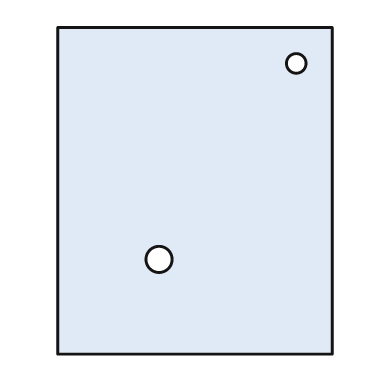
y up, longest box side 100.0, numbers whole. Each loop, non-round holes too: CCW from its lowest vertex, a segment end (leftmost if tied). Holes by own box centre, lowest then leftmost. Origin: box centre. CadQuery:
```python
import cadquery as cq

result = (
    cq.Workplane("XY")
    .moveTo(-42.0, -50.0)
    .lineTo(42.0, -50.0)
    .lineTo(42.0, 50.0)
    .lineTo(-42.0, 50.0)
    .close()
    .moveTo(-11.0, -21.0)
    .circle(4.0)
    .moveTo(31.0, 39.0)
    .circle(3.0)
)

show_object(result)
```